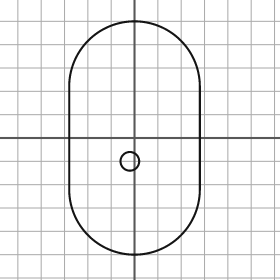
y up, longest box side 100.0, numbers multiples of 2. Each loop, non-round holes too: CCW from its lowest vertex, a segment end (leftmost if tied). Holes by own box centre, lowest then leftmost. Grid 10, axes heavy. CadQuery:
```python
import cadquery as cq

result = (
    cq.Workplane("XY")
    .moveTo(-28.0, -22.0)
    .threePointArc((0.0, -50.0), (28.0, -22.0))
    .lineTo(28.0, 22.0)
    .threePointArc((0.0, 50.0), (-28.0, 22.0))
    .close()
    .moveTo(-2.0, -10.0)
    .circle(4.0)
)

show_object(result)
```